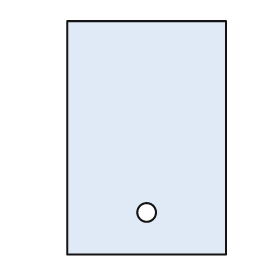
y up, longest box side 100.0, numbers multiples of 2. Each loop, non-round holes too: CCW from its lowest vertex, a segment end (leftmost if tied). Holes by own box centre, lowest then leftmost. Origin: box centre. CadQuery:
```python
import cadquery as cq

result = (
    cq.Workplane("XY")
    .moveTo(-34.0, -50.0)
    .lineTo(34.0, -50.0)
    .lineTo(34.0, 50.0)
    .lineTo(-34.0, 50.0)
    .close()
    .moveTo(0.0, -32.0)
    .circle(4.0)
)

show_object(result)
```